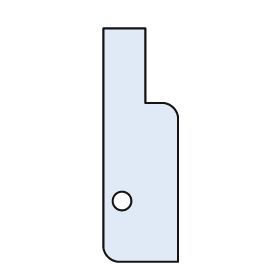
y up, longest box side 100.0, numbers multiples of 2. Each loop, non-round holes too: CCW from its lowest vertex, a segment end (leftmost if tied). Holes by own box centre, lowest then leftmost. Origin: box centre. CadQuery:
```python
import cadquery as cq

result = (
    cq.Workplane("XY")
    .moveTo(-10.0, -50.0)
    .lineTo(16.0, -50.0)
    .lineTo(16.0, 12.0)
    .threePointArc((14.0, 16.0), (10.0, 18.0))
    .lineTo(2.0, 18.0)
    .lineTo(2.0, 50.0)
    .lineTo(-16.0, 50.0)
    .lineTo(-16.0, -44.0)
    .threePointArc((-14.0, -48.0), (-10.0, -50.0))
    .close()
    .moveTo(-8.0, -24.0)
    .circle(4.0)
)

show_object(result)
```